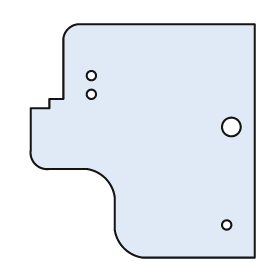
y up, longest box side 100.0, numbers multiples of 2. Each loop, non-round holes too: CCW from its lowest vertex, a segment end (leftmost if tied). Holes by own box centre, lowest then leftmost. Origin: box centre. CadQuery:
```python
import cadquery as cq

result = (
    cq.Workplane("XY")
    .moveTo(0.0, -50.0)
    .lineTo(48.0, -50.0)
    .lineTo(48.0, 50.0)
    .lineTo(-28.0, 50.0)
    .threePointArc((-32.0, 48.0), (-34.0, 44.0))
    .lineTo(-34.0, 18.0)
    .lineTo(-40.0, 18.0)
    .lineTo(-40.0, 14.0)
    .lineTo(-48.0, 14.0)
    .lineTo(-48.0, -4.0)
    .threePointArc((-46.0, -10.0), (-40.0, -12.0))
    .lineTo(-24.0, -12.0)
    .threePointArc((-16.0, -16.0), (-12.0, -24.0))
    .lineTo(-12.0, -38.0)
    .threePointArc((-8.0, -46.0), (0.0, -50.0))
    .close()
    .moveTo(36.0, -36.0)
    .circle(2.0)
    .moveTo(38.0, 6.0)
    .circle(4.0)
    .moveTo(-22.0, 20.0)
    .circle(2.0)
    .moveTo(-22.0, 28.0)
    .circle(2.0)
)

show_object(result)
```